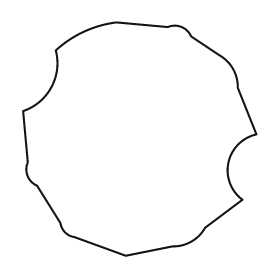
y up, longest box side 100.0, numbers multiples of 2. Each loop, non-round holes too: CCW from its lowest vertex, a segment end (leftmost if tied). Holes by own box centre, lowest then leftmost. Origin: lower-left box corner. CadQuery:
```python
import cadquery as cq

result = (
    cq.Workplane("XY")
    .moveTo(44.0, 0.0)
    .lineTo(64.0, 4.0)
    .threePointArc((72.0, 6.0), (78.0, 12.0))
    .lineTo(94.0, 24.0)
    .threePointArc((88.0, 40.0), (100.0, 52.0))
    .lineTo(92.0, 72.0)
    .threePointArc((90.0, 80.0), (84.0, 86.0))
    .lineTo(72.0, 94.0)
    .threePointArc((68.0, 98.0), (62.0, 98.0))
    .lineTo(40.0, 100.0)
    .threePointArc((26.0, 96.0), (14.0, 88.0))
    .threePointArc((12.0, 72.0), (0.0, 62.0))
    .lineTo(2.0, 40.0)
    .threePointArc((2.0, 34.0), (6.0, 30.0))
    .lineTo(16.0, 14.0)
    .threePointArc((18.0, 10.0), (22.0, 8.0))
    .close()
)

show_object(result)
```